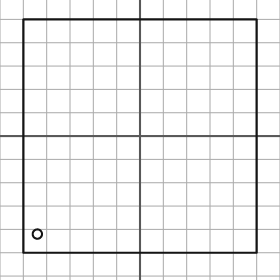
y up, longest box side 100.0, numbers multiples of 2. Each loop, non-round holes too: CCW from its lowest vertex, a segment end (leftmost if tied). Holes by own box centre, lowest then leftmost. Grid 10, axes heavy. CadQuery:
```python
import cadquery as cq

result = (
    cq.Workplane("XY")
    .moveTo(-50.0, -50.0)
    .lineTo(50.0, -50.0)
    .lineTo(50.0, 50.0)
    .lineTo(-50.0, 50.0)
    .close()
    .moveTo(-44.0, -42.0)
    .circle(2.0)
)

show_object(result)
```